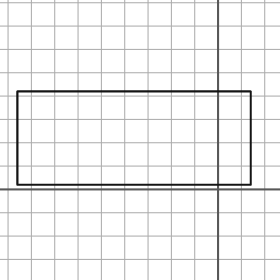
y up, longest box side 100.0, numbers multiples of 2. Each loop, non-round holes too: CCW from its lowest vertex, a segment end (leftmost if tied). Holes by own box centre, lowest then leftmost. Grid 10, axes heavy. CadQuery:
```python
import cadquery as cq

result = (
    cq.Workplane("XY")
    .moveTo(-86.0, 2.0)
    .lineTo(14.0, 2.0)
    .lineTo(14.0, 42.0)
    .lineTo(-86.0, 42.0)
    .close()
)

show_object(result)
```